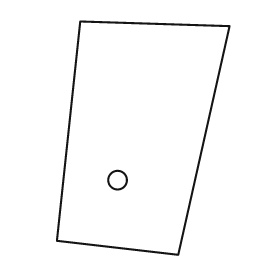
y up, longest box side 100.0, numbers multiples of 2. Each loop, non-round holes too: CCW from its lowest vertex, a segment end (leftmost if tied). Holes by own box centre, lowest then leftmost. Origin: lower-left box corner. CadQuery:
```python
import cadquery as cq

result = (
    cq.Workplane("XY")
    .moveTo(52.0, 0.0)
    .lineTo(74.0, 98.0)
    .lineTo(10.0, 100.0)
    .lineTo(0.0, 6.0)
    .close()
    .moveTo(26.0, 32.0)
    .circle(4.0)
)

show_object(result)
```